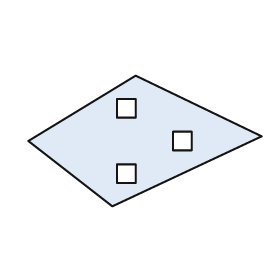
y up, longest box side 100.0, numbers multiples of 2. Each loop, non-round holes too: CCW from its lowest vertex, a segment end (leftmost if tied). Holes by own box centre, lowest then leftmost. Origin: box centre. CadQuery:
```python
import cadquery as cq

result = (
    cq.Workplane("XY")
    .moveTo(-14.0, -28.0)
    .lineTo(50.0, 2.0)
    .lineTo(-4.0, 28.0)
    .lineTo(-50.0, 0.0)
    .close()
    .moveTo(-12.0, -18.0)
    .lineTo(-4.0, -18.0)
    .lineTo(-4.0, -10.0)
    .lineTo(-12.0, -10.0)
    .close()
    .moveTo(12.0, -4.0)
    .lineTo(20.0, -4.0)
    .lineTo(20.0, 4.0)
    .lineTo(12.0, 4.0)
    .close()
    .moveTo(-12.0, 10.0)
    .lineTo(-4.0, 10.0)
    .lineTo(-4.0, 18.0)
    .lineTo(-12.0, 18.0)
    .close()
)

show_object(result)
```